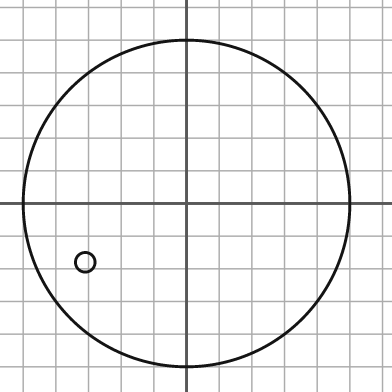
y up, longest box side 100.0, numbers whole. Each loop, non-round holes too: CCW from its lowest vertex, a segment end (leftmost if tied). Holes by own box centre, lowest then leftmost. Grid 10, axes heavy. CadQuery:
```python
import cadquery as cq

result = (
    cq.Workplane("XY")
    .moveTo(0.0, 0.0)
    .circle(50.0)
    .moveTo(-31.0, -18.0)
    .circle(3.0)
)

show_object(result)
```